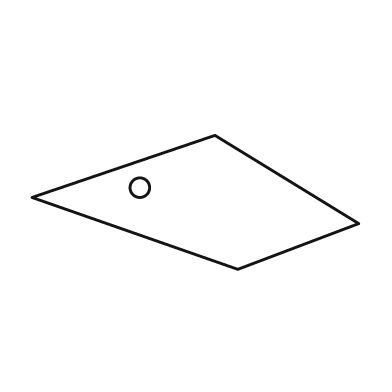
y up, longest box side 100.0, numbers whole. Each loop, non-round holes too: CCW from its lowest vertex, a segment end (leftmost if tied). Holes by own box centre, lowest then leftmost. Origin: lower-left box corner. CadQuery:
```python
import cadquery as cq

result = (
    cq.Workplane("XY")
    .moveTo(63.0, 0.0)
    .lineTo(100.0, 14.0)
    .lineTo(56.0, 41.0)
    .lineTo(0.0, 22.0)
    .close()
    .moveTo(33.0, 25.0)
    .circle(3.0)
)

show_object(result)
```